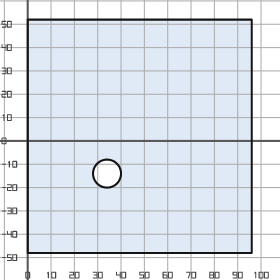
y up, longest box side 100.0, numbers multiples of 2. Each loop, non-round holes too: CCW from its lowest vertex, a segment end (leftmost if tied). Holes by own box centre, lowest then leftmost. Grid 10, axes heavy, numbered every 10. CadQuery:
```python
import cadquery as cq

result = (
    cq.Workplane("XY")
    .moveTo(0.0, -48.0)
    .lineTo(96.0, -48.0)
    .lineTo(96.0, 52.0)
    .lineTo(0.0, 52.0)
    .close()
    .moveTo(34.0, -14.0)
    .circle(6.0)
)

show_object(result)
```